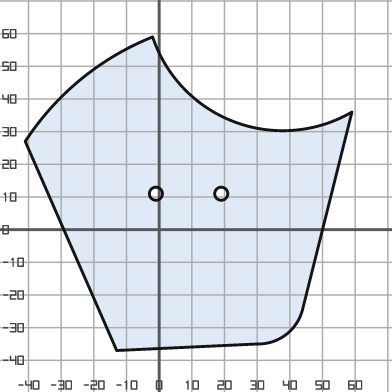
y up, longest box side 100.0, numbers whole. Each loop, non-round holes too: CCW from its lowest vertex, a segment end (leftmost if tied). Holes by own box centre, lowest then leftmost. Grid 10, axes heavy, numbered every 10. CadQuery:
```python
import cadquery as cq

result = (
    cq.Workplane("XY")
    .moveTo(-13.0, -37.0)
    .lineTo(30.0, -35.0)
    .threePointArc((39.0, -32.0), (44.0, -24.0))
    .lineTo(59.0, 36.0)
    .threePointArc((23.0, 33.0), (-2.0, 59.0))
    .threePointArc((-24.0, 46.0), (-41.0, 27.0))
    .close()
    .moveTo(-1.0, 11.0)
    .circle(2.0)
    .moveTo(19.0, 11.0)
    .circle(2.0)
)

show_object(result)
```